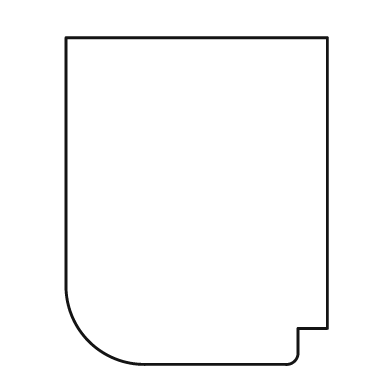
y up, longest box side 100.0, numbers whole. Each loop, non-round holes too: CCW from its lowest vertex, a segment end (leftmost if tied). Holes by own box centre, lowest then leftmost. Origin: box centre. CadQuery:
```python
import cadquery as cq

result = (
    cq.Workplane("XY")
    .moveTo(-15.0, -50.0)
    .lineTo(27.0, -50.0)
    .threePointArc((30.0, -49.0), (31.0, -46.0))
    .lineTo(31.0, -39.0)
    .lineTo(40.0, -39.0)
    .lineTo(40.0, 50.0)
    .lineTo(-40.0, 50.0)
    .lineTo(-40.0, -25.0)
    .threePointArc((-33.0, -43.0), (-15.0, -50.0))
    .close()
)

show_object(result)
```